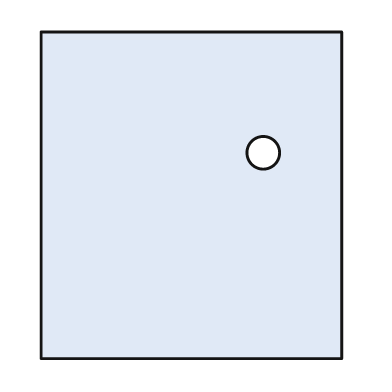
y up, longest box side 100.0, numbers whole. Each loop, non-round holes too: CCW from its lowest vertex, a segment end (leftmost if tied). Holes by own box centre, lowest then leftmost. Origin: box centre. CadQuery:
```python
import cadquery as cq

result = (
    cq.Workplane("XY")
    .moveTo(-46.0, -50.0)
    .lineTo(46.0, -50.0)
    .lineTo(46.0, 50.0)
    .lineTo(-46.0, 50.0)
    .close()
    .moveTo(22.0, 13.0)
    .circle(5.0)
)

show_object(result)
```